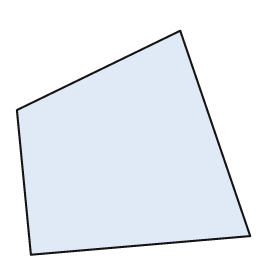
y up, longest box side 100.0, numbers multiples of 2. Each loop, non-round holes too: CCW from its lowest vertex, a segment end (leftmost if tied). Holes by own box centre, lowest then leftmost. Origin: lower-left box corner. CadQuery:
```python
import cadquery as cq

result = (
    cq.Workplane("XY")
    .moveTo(6.0, 0.0)
    .lineTo(100.0, 8.0)
    .lineTo(70.0, 96.0)
    .lineTo(0.0, 62.0)
    .close()
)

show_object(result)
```